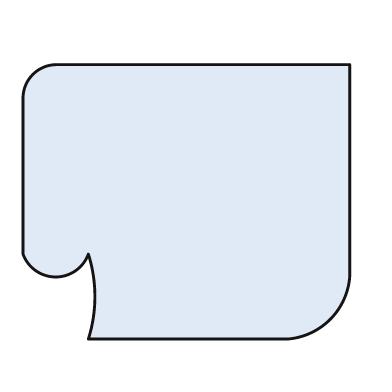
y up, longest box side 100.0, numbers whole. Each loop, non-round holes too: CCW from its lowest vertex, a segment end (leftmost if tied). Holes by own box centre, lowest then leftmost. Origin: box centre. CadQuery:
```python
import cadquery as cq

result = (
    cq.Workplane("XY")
    .moveTo(-30.0, -42.0)
    .lineTo(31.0, -42.0)
    .threePointArc((44.0, -36.0), (50.0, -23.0))
    .lineTo(50.0, 42.0)
    .lineTo(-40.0, 42.0)
    .threePointArc((-47.0, 39.0), (-50.0, 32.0))
    .lineTo(-50.0, -16.0)
    .threePointArc((-40.0, -23.0), (-30.0, -16.0))
    .threePointArc((-28.0, -29.0), (-30.0, -42.0))
    .close()
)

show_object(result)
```